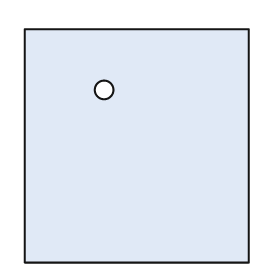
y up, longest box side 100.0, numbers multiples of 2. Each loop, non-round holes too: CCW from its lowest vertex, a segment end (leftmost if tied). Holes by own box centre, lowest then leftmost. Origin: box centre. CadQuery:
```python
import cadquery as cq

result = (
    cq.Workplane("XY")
    .moveTo(-48.0, -50.0)
    .lineTo(48.0, -50.0)
    .lineTo(48.0, 50.0)
    .lineTo(-48.0, 50.0)
    .close()
    .moveTo(-14.0, 24.0)
    .circle(4.0)
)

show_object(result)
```